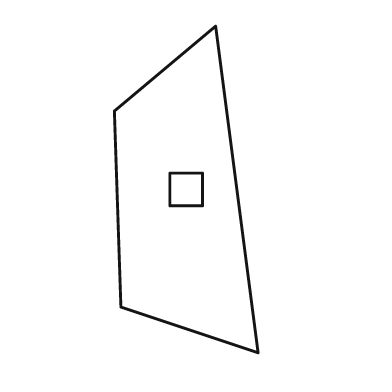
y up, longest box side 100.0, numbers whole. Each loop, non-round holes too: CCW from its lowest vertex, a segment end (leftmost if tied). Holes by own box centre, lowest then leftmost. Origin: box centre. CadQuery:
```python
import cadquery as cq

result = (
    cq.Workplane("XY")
    .moveTo(22.0, -50.0)
    .lineTo(9.0, 50.0)
    .lineTo(-22.0, 24.0)
    .lineTo(-20.0, -36.0)
    .close()
    .moveTo(-5.0, -5.0)
    .lineTo(5.0, -5.0)
    .lineTo(5.0, 5.0)
    .lineTo(-5.0, 5.0)
    .close()
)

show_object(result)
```